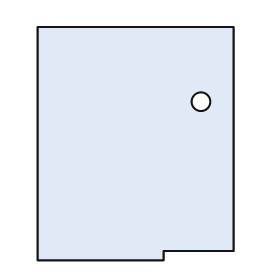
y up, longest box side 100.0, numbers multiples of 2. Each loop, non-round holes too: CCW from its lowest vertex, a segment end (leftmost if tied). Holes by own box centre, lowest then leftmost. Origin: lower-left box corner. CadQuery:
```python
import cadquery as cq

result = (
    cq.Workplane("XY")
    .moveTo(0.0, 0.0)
    .lineTo(54.0, 0.0)
    .lineTo(54.0, 4.0)
    .lineTo(84.0, 4.0)
    .lineTo(84.0, 100.0)
    .lineTo(0.0, 100.0)
    .close()
    .moveTo(70.0, 68.0)
    .circle(4.0)
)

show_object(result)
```